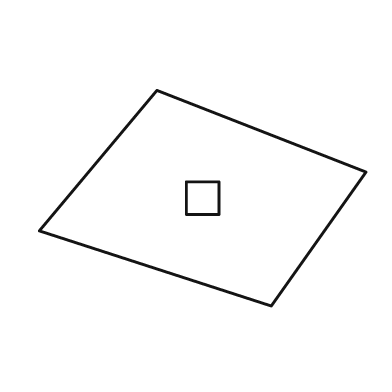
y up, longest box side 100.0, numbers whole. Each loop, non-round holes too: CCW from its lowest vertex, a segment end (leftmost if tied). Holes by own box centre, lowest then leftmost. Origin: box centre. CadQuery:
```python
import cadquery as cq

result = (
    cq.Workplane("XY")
    .moveTo(21.0, -33.0)
    .lineTo(50.0, 8.0)
    .lineTo(-14.0, 33.0)
    .lineTo(-50.0, -10.0)
    .close()
    .moveTo(-5.0, -5.0)
    .lineTo(5.0, -5.0)
    .lineTo(5.0, 5.0)
    .lineTo(-5.0, 5.0)
    .close()
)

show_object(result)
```